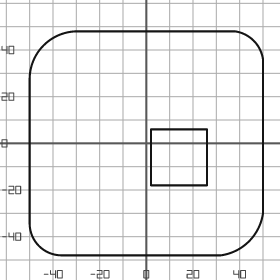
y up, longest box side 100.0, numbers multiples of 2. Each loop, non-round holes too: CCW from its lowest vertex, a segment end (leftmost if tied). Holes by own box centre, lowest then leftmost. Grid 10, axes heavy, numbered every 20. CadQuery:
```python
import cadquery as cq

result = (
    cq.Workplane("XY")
    .moveTo(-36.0, -48.0)
    .lineTo(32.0, -48.0)
    .threePointArc((44.0, -42.0), (50.0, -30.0))
    .lineTo(50.0, 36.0)
    .threePointArc((46.0, 44.0), (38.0, 48.0))
    .lineTo(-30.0, 48.0)
    .threePointArc((-44.0, 42.0), (-50.0, 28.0))
    .lineTo(-50.0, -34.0)
    .threePointArc((-46.0, -44.0), (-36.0, -48.0))
    .close()
    .moveTo(2.0, -18.0)
    .lineTo(26.0, -18.0)
    .lineTo(26.0, 6.0)
    .lineTo(2.0, 6.0)
    .close()
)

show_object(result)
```